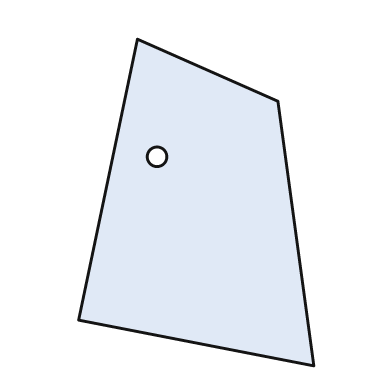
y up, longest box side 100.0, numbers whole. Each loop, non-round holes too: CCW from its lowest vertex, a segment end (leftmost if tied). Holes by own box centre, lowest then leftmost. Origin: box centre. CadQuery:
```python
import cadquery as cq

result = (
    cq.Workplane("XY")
    .moveTo(36.0, -50.0)
    .lineTo(25.0, 31.0)
    .lineTo(-18.0, 50.0)
    .lineTo(-36.0, -36.0)
    .close()
    .moveTo(-12.0, 14.0)
    .circle(3.0)
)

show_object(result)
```